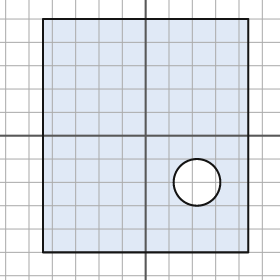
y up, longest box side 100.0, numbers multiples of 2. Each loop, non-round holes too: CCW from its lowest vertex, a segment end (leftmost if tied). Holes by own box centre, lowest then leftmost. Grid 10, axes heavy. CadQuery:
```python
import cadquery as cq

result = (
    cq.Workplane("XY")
    .moveTo(-44.0, -50.0)
    .lineTo(44.0, -50.0)
    .lineTo(44.0, 50.0)
    .lineTo(-44.0, 50.0)
    .close()
    .moveTo(22.0, -20.0)
    .circle(10.0)
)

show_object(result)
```